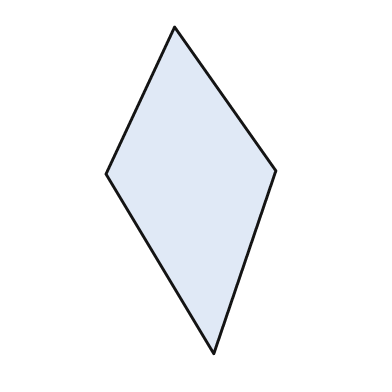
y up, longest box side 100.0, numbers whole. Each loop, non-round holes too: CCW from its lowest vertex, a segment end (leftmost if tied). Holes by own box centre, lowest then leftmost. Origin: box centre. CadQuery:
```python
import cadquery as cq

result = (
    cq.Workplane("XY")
    .moveTo(7.0, -50.0)
    .lineTo(26.0, 6.0)
    .lineTo(-5.0, 50.0)
    .lineTo(-26.0, 5.0)
    .close()
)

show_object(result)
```